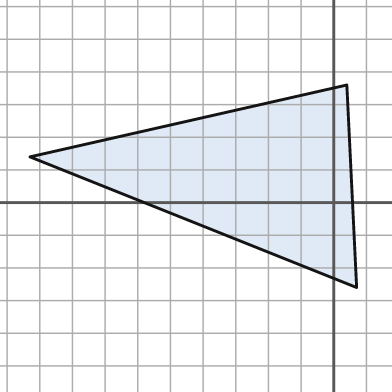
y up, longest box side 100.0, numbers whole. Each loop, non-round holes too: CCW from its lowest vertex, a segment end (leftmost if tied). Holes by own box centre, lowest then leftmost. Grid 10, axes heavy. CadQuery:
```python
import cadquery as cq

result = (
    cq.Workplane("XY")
    .moveTo(7.0, -26.0)
    .lineTo(4.0, 36.0)
    .lineTo(-93.0, 14.0)
    .close()
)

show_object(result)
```